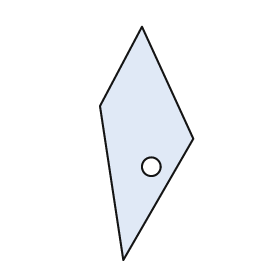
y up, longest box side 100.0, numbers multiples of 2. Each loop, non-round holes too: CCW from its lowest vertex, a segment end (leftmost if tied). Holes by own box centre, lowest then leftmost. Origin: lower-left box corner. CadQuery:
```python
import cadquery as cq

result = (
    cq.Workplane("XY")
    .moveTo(10.0, 0.0)
    .lineTo(40.0, 52.0)
    .lineTo(18.0, 100.0)
    .lineTo(0.0, 66.0)
    .close()
    .moveTo(22.0, 40.0)
    .circle(4.0)
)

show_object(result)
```